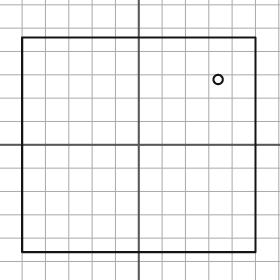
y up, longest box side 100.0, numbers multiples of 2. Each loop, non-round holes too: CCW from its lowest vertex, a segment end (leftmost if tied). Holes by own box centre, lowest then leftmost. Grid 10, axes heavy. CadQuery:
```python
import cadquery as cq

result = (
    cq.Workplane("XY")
    .moveTo(-50.0, -46.0)
    .lineTo(50.0, -46.0)
    .lineTo(50.0, 46.0)
    .lineTo(-50.0, 46.0)
    .close()
    .moveTo(34.0, 28.0)
    .circle(2.0)
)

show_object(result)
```